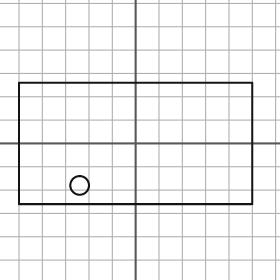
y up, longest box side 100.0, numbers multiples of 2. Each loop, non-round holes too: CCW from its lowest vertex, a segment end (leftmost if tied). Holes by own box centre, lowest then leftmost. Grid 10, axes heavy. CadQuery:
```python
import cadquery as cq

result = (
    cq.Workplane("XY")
    .moveTo(-50.0, -26.0)
    .lineTo(50.0, -26.0)
    .lineTo(50.0, 26.0)
    .lineTo(-50.0, 26.0)
    .close()
    .moveTo(-24.0, -18.0)
    .circle(4.0)
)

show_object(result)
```